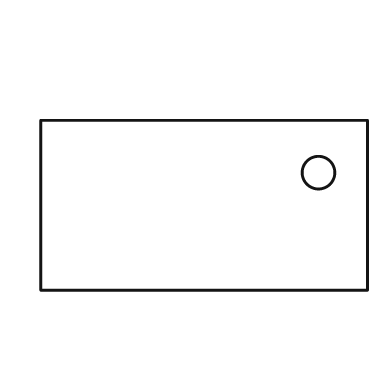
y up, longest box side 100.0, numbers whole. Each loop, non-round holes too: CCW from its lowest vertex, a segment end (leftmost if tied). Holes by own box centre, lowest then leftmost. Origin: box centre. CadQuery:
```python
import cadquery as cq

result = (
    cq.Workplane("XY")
    .moveTo(-50.0, -26.0)
    .lineTo(50.0, -26.0)
    .lineTo(50.0, 26.0)
    .lineTo(-50.0, 26.0)
    .close()
    .moveTo(35.0, 10.0)
    .circle(5.0)
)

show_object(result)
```